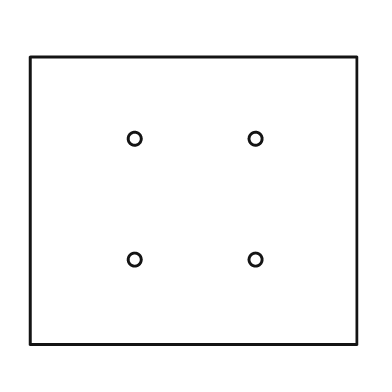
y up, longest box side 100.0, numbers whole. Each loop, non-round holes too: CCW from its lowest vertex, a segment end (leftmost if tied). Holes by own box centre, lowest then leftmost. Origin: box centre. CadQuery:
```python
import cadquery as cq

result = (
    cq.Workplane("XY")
    .moveTo(-50.0, -44.0)
    .lineTo(50.0, -44.0)
    .lineTo(50.0, 44.0)
    .lineTo(-50.0, 44.0)
    .close()
    .moveTo(-18.0, -18.0)
    .circle(2.0)
    .moveTo(19.0, -18.0)
    .circle(2.0)
    .moveTo(-18.0, 19.0)
    .circle(2.0)
    .moveTo(19.0, 19.0)
    .circle(2.0)
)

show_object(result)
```